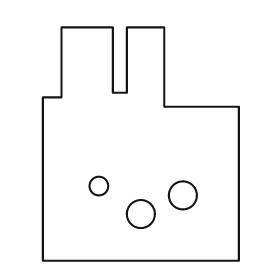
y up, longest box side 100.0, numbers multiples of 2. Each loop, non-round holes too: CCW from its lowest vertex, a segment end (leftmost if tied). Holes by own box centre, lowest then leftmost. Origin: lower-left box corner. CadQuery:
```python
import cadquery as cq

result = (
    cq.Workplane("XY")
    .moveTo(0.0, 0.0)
    .lineTo(84.0, 0.0)
    .lineTo(84.0, 66.0)
    .lineTo(52.0, 66.0)
    .lineTo(52.0, 100.0)
    .lineTo(36.0, 100.0)
    .lineTo(36.0, 72.0)
    .lineTo(30.0, 72.0)
    .lineTo(30.0, 100.0)
    .lineTo(8.0, 100.0)
    .lineTo(8.0, 70.0)
    .lineTo(0.0, 70.0)
    .close()
    .moveTo(42.0, 20.0)
    .circle(6.0)
    .moveTo(60.0, 28.0)
    .circle(6.0)
    .moveTo(24.0, 32.0)
    .circle(4.0)
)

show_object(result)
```